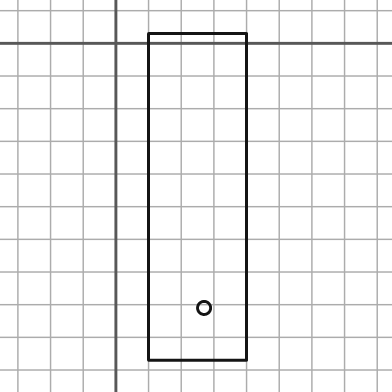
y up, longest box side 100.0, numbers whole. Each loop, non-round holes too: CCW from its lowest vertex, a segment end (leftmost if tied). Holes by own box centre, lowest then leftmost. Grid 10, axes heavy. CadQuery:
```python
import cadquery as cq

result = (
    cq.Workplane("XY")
    .moveTo(10.0, -97.0)
    .lineTo(40.0, -97.0)
    .lineTo(40.0, 3.0)
    .lineTo(10.0, 3.0)
    .close()
    .moveTo(27.0, -81.0)
    .circle(2.0)
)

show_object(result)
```